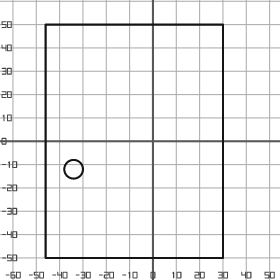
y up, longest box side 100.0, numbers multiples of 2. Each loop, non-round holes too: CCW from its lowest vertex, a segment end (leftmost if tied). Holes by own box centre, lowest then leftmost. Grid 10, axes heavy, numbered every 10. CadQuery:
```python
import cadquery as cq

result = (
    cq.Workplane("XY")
    .moveTo(-46.0, -50.0)
    .lineTo(30.0, -50.0)
    .lineTo(30.0, 50.0)
    .lineTo(-46.0, 50.0)
    .close()
    .moveTo(-34.0, -12.0)
    .circle(4.0)
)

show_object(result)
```